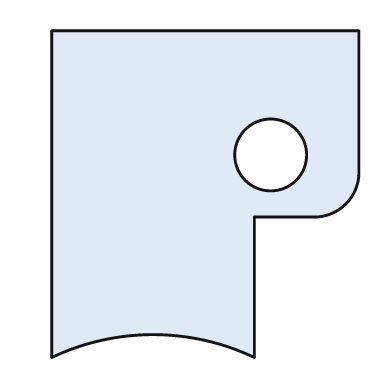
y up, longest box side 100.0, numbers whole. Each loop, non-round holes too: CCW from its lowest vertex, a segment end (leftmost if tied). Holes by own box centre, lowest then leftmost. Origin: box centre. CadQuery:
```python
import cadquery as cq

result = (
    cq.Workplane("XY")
    .moveTo(-47.0, -50.0)
    .threePointArc((-16.0, -43.0), (15.0, -50.0))
    .lineTo(15.0, -7.0)
    .lineTo(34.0, -7.0)
    .threePointArc((43.0, -3.0), (47.0, 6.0))
    .lineTo(47.0, 50.0)
    .lineTo(-47.0, 50.0)
    .close()
    .moveTo(20.0, 12.0)
    .circle(11.0)
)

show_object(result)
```